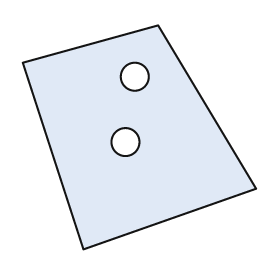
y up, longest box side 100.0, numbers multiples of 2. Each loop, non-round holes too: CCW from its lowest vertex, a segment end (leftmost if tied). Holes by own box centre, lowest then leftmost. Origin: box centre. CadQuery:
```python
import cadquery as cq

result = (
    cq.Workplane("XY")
    .moveTo(-24.0, -48.0)
    .lineTo(50.0, -22.0)
    .lineTo(8.0, 48.0)
    .lineTo(-50.0, 32.0)
    .close()
    .moveTo(-6.0, -2.0)
    .circle(6.0)
    .moveTo(-2.0, 26.0)
    .circle(6.0)
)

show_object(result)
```